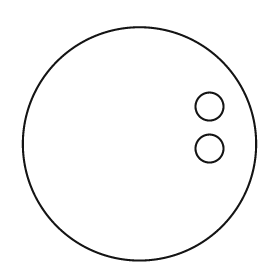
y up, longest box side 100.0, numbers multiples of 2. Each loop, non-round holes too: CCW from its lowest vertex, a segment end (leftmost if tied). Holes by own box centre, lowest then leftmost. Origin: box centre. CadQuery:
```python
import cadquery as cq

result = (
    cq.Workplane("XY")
    .moveTo(0.0, 0.0)
    .circle(50.0)
    .moveTo(30.0, -2.0)
    .circle(6.0)
    .moveTo(30.0, 16.0)
    .circle(6.0)
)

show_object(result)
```